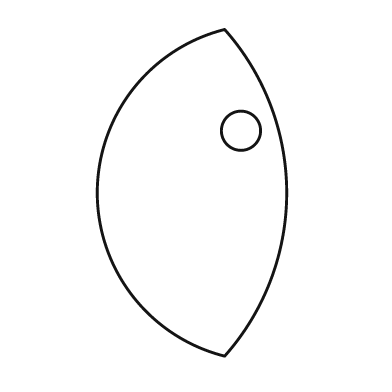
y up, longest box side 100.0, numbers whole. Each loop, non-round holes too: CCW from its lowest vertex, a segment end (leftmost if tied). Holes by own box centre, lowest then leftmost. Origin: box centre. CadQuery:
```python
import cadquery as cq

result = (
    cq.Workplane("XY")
    .moveTo(10.0, -50.0)
    .threePointArc((29.0, 0.0), (10.0, 50.0))
    .threePointArc((-29.0, 0.0), (10.0, -50.0))
    .close()
    .moveTo(15.0, 19.0)
    .circle(6.0)
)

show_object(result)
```